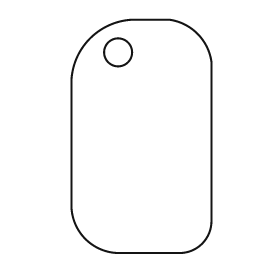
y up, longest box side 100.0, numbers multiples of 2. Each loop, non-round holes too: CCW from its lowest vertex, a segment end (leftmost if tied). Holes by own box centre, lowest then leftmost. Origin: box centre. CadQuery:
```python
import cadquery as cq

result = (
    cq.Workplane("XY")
    .moveTo(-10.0, -50.0)
    .lineTo(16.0, -50.0)
    .threePointArc((26.0, -46.0), (30.0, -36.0))
    .lineTo(30.0, 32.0)
    .threePointArc((24.0, 44.0), (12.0, 50.0))
    .lineTo(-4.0, 50.0)
    .threePointArc((-22.0, 42.0), (-30.0, 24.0))
    .lineTo(-30.0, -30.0)
    .threePointArc((-24.0, -44.0), (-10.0, -50.0))
    .close()
    .moveTo(-10.0, 36.0)
    .circle(6.0)
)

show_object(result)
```